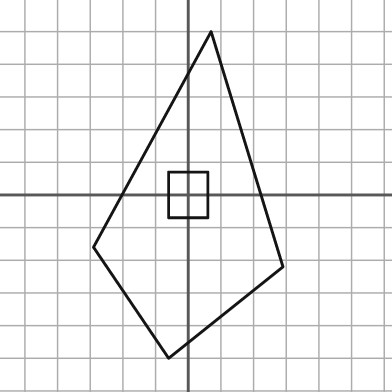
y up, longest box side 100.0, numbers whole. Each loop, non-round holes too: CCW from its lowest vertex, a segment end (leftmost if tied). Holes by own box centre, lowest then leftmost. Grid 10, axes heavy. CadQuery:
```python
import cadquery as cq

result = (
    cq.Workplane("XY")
    .moveTo(-6.0, -50.0)
    .lineTo(29.0, -22.0)
    .lineTo(7.0, 50.0)
    .lineTo(-29.0, -16.0)
    .close()
    .moveTo(-6.0, -7.0)
    .lineTo(6.0, -7.0)
    .lineTo(6.0, 7.0)
    .lineTo(-6.0, 7.0)
    .close()
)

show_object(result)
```